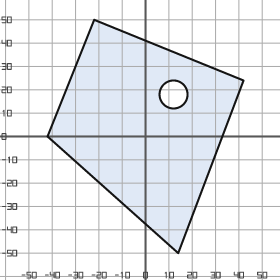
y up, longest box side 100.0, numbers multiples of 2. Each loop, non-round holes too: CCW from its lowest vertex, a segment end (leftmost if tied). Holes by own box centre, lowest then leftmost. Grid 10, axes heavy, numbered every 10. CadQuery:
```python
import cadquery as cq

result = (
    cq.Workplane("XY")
    .moveTo(14.0, -50.0)
    .lineTo(42.0, 24.0)
    .lineTo(-22.0, 50.0)
    .lineTo(-42.0, 0.0)
    .close()
    .moveTo(12.0, 18.0)
    .circle(6.0)
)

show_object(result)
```